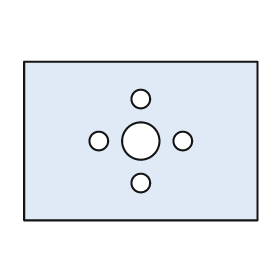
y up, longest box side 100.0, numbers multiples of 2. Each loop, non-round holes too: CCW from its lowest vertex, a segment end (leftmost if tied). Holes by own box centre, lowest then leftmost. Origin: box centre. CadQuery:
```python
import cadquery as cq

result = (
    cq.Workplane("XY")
    .moveTo(-50.0, -34.0)
    .lineTo(50.0, -34.0)
    .lineTo(50.0, 34.0)
    .lineTo(-50.0, 34.0)
    .close()
    .moveTo(0.0, -18.0)
    .circle(4.0)
    .moveTo(-18.0, 0.0)
    .circle(4.0)
    .moveTo(0.0, 0.0)
    .circle(8.0)
    .moveTo(18.0, 0.0)
    .circle(4.0)
    .moveTo(0.0, 18.0)
    .circle(4.0)
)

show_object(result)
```